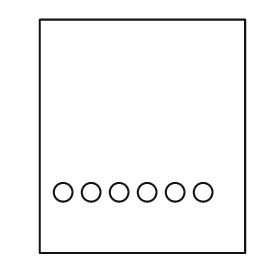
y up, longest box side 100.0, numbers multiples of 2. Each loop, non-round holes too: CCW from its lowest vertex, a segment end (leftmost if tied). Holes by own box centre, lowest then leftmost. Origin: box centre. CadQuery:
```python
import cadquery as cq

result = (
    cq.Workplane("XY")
    .moveTo(-44.0, -50.0)
    .lineTo(44.0, -50.0)
    .lineTo(44.0, 50.0)
    .lineTo(-44.0, 50.0)
    .close()
    .moveTo(-34.0, -24.0)
    .circle(4.0)
    .moveTo(-22.0, -24.0)
    .circle(4.0)
    .moveTo(-10.0, -24.0)
    .circle(4.0)
    .moveTo(2.0, -24.0)
    .circle(4.0)
    .moveTo(14.0, -24.0)
    .circle(4.0)
    .moveTo(26.0, -24.0)
    .circle(4.0)
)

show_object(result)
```